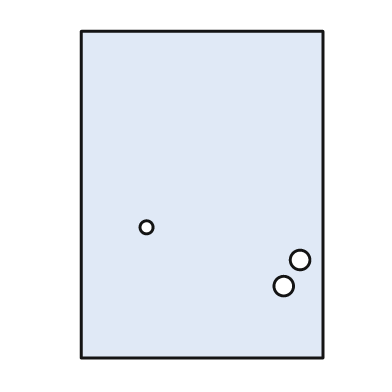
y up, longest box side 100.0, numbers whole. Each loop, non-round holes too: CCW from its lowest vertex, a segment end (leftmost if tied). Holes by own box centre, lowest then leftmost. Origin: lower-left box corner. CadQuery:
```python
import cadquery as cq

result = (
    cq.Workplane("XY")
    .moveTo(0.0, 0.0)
    .lineTo(74.0, 0.0)
    .lineTo(74.0, 100.0)
    .lineTo(0.0, 100.0)
    .close()
    .moveTo(62.0, 22.0)
    .circle(3.0)
    .moveTo(67.0, 30.0)
    .circle(3.0)
    .moveTo(20.0, 40.0)
    .circle(2.0)
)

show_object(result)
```